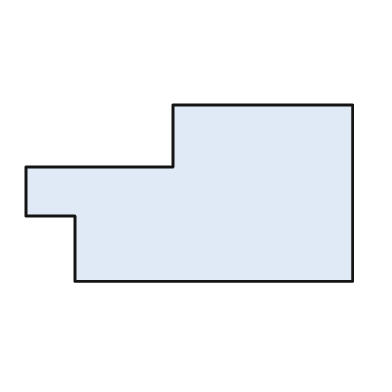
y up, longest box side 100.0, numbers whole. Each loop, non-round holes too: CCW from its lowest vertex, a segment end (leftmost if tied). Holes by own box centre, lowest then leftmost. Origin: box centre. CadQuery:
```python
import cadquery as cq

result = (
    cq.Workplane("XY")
    .moveTo(-35.0, -27.0)
    .lineTo(50.0, -27.0)
    .lineTo(50.0, 27.0)
    .lineTo(-5.0, 27.0)
    .lineTo(-5.0, 8.0)
    .lineTo(-50.0, 8.0)
    .lineTo(-50.0, -7.0)
    .lineTo(-35.0, -7.0)
    .close()
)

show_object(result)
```